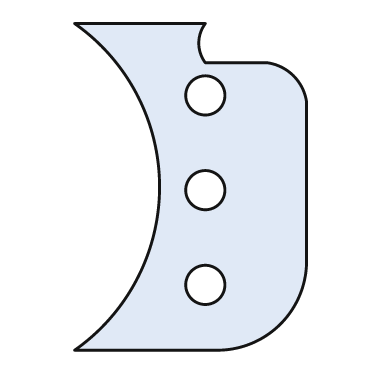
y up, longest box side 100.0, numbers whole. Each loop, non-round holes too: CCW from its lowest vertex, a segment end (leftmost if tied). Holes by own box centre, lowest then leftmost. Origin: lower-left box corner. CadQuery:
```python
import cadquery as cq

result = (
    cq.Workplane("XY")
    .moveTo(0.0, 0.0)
    .lineTo(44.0, 0.0)
    .threePointArc((63.0, 8.0), (71.0, 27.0))
    .lineTo(71.0, 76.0)
    .threePointArc((67.0, 84.0), (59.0, 88.0))
    .lineTo(40.0, 88.0)
    .threePointArc((38.0, 94.0), (40.0, 100.0))
    .lineTo(0.0, 100.0)
    .threePointArc((26.0, 50.0), (0.0, 0.0))
    .close()
    .moveTo(40.0, 20.0)
    .circle(6.0)
    .moveTo(40.0, 49.0)
    .circle(6.0)
    .moveTo(40.0, 78.0)
    .circle(6.0)
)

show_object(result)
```